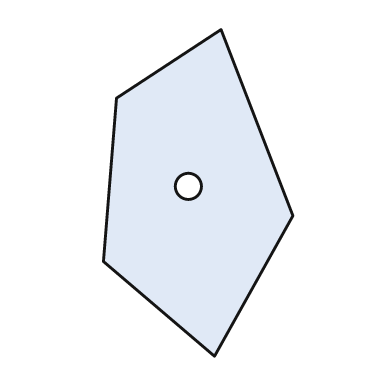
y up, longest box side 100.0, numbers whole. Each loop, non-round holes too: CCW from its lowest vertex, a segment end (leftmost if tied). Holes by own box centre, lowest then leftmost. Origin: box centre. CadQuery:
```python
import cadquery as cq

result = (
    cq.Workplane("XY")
    .moveTo(5.0, -50.0)
    .lineTo(29.0, -7.0)
    .lineTo(7.0, 50.0)
    .lineTo(-25.0, 29.0)
    .lineTo(-29.0, -21.0)
    .close()
    .moveTo(-3.0, 2.0)
    .circle(4.0)
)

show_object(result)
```